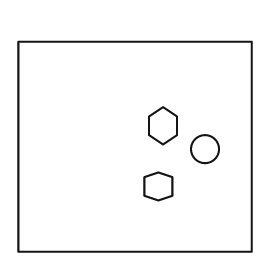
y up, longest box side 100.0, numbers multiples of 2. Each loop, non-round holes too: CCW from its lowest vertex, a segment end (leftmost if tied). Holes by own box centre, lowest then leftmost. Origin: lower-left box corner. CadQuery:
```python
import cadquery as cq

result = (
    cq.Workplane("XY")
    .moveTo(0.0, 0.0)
    .lineTo(100.0, 0.0)
    .lineTo(100.0, 90.0)
    .lineTo(0.0, 90.0)
    .close()
    .moveTo(60.0, 22.0)
    .lineTo(66.0, 24.0)
    .lineTo(66.0, 32.0)
    .lineTo(60.0, 34.0)
    .lineTo(54.0, 32.0)
    .lineTo(54.0, 24.0)
    .close()
    .moveTo(80.0, 44.0)
    .circle(6.0)
    .moveTo(62.0, 46.0)
    .lineTo(68.0, 50.0)
    .lineTo(68.0, 58.0)
    .lineTo(62.0, 62.0)
    .lineTo(56.0, 58.0)
    .lineTo(56.0, 50.0)
    .close()
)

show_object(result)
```